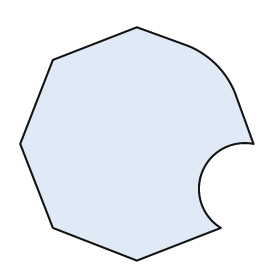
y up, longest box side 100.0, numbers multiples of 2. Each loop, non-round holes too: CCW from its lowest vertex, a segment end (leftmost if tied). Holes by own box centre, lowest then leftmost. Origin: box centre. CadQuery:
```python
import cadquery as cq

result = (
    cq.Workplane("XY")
    .moveTo(0.0, -50.0)
    .lineTo(36.0, -36.0)
    .threePointArc((28.0, -12.0), (50.0, 0.0))
    .lineTo(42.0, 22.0)
    .threePointArc((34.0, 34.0), (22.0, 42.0))
    .lineTo(0.0, 50.0)
    .lineTo(-36.0, 36.0)
    .lineTo(-50.0, 0.0)
    .lineTo(-36.0, -36.0)
    .close()
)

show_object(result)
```